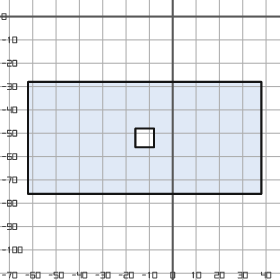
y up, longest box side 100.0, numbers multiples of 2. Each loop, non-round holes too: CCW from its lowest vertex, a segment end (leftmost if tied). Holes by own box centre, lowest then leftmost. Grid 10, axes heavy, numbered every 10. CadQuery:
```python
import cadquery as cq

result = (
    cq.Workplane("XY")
    .moveTo(-62.0, -76.0)
    .lineTo(38.0, -76.0)
    .lineTo(38.0, -28.0)
    .lineTo(-62.0, -28.0)
    .close()
    .moveTo(-16.0, -56.0)
    .lineTo(-8.0, -56.0)
    .lineTo(-8.0, -48.0)
    .lineTo(-16.0, -48.0)
    .close()
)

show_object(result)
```